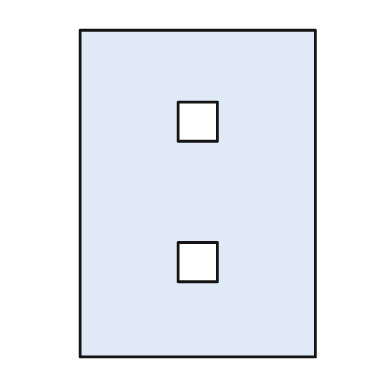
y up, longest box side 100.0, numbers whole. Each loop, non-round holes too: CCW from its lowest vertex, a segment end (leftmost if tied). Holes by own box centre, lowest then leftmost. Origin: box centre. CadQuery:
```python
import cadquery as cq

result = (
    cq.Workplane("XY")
    .moveTo(-36.0, -50.0)
    .lineTo(36.0, -50.0)
    .lineTo(36.0, 50.0)
    .lineTo(-36.0, 50.0)
    .close()
    .moveTo(-6.0, -27.0)
    .lineTo(6.0, -27.0)
    .lineTo(6.0, -15.0)
    .lineTo(-6.0, -15.0)
    .close()
    .moveTo(-6.0, 16.0)
    .lineTo(6.0, 16.0)
    .lineTo(6.0, 28.0)
    .lineTo(-6.0, 28.0)
    .close()
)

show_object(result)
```